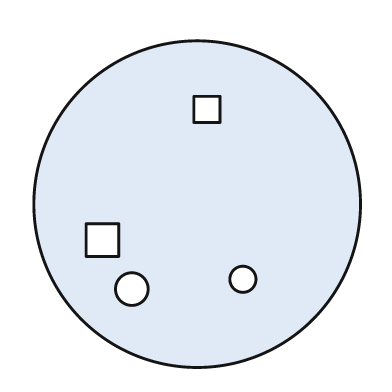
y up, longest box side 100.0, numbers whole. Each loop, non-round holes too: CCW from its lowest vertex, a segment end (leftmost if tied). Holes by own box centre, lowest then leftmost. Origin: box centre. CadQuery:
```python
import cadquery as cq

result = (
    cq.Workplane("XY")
    .moveTo(0.0, 0.0)
    .circle(50.0)
    .moveTo(-20.0, -26.0)
    .circle(5.0)
    .moveTo(14.0, -23.0)
    .circle(4.0)
    .moveTo(-34.0, -16.0)
    .lineTo(-24.0, -16.0)
    .lineTo(-24.0, -6.0)
    .lineTo(-34.0, -6.0)
    .close()
    .moveTo(-1.0, 25.0)
    .lineTo(7.0, 25.0)
    .lineTo(7.0, 33.0)
    .lineTo(-1.0, 33.0)
    .close()
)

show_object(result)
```